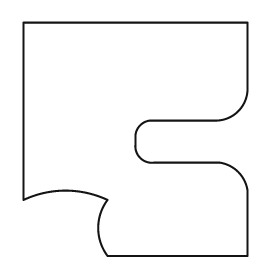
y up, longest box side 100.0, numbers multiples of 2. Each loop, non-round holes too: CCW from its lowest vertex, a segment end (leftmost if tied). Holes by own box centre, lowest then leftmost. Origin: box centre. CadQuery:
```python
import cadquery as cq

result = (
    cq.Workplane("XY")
    .moveTo(-12.0, -50.0)
    .lineTo(48.0, -50.0)
    .lineTo(48.0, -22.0)
    .threePointArc((44.0, -14.0), (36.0, -10.0))
    .lineTo(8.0, -10.0)
    .threePointArc((2.0, -8.0), (0.0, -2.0))
    .lineTo(0.0, 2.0)
    .threePointArc((2.0, 6.0), (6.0, 8.0))
    .lineTo(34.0, 8.0)
    .threePointArc((44.0, 12.0), (48.0, 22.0))
    .lineTo(48.0, 50.0)
    .lineTo(-48.0, 50.0)
    .lineTo(-48.0, -26.0)
    .threePointArc((-30.0, -22.0), (-12.0, -26.0))
    .threePointArc((-16.0, -38.0), (-12.0, -50.0))
    .close()
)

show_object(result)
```